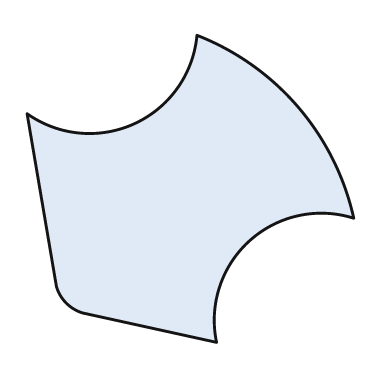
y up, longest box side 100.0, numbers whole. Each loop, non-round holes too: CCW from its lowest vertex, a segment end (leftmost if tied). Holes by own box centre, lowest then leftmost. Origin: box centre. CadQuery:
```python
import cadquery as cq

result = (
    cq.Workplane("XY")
    .moveTo(8.0, -47.0)
    .threePointArc((18.0, -16.0), (50.0, -9.0))
    .threePointArc((33.0, 25.0), (2.0, 47.0))
    .threePointArc((-17.0, 20.0), (-50.0, 23.0))
    .lineTo(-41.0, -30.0)
    .threePointArc((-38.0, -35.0), (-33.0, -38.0))
    .close()
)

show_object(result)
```